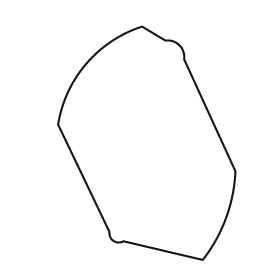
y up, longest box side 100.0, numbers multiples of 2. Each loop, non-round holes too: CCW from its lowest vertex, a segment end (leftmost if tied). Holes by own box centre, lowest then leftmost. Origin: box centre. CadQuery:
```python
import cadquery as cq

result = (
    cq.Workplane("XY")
    .moveTo(24.0, -50.0)
    .threePointArc((34.0, -32.0), (38.0, -12.0))
    .lineTo(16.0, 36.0)
    .threePointArc((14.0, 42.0), (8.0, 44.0))
    .lineTo(-2.0, 50.0)
    .threePointArc((-26.0, 34.0), (-38.0, 8.0))
    .lineTo(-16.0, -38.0)
    .threePointArc((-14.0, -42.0), (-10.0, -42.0))
    .close()
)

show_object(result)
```